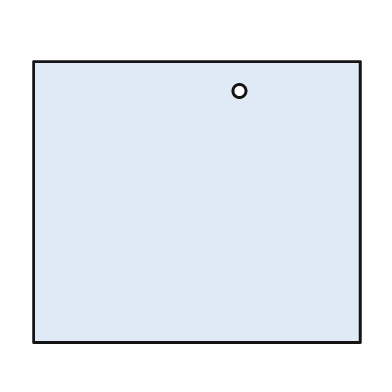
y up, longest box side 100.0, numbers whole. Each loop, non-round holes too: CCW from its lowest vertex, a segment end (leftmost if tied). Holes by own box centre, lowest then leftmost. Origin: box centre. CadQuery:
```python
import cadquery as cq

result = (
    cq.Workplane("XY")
    .moveTo(-50.0, -43.0)
    .lineTo(50.0, -43.0)
    .lineTo(50.0, 43.0)
    .lineTo(-50.0, 43.0)
    .close()
    .moveTo(13.0, 34.0)
    .circle(2.0)
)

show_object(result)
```